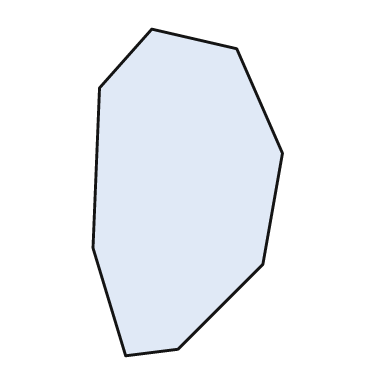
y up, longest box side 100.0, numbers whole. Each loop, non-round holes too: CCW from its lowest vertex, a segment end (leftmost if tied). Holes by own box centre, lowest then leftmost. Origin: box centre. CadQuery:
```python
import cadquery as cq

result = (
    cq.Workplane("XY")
    .moveTo(-19.0, -50.0)
    .lineTo(-3.0, -48.0)
    .lineTo(23.0, -22.0)
    .lineTo(29.0, 12.0)
    .lineTo(15.0, 44.0)
    .lineTo(-11.0, 50.0)
    .lineTo(-27.0, 32.0)
    .lineTo(-29.0, -17.0)
    .close()
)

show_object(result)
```